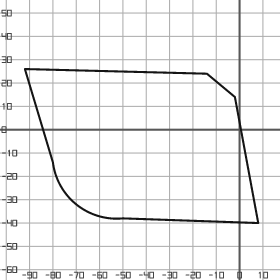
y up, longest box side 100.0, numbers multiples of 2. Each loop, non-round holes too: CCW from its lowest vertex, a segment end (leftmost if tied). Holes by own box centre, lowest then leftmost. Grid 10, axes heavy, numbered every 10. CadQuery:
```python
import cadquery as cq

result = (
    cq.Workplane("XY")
    .moveTo(8.0, -40.0)
    .lineTo(-2.0, 14.0)
    .lineTo(-14.0, 24.0)
    .lineTo(-92.0, 26.0)
    .lineTo(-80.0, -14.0)
    .threePointArc((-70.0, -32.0), (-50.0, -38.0))
    .close()
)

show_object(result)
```